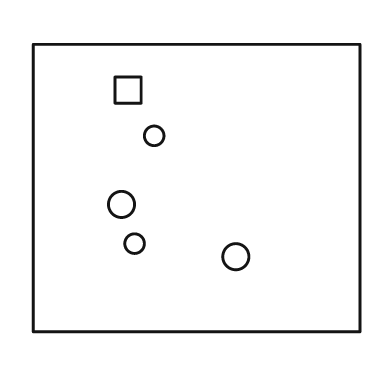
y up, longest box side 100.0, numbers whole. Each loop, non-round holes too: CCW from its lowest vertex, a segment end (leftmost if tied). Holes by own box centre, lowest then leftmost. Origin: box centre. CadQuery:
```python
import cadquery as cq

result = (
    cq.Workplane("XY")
    .moveTo(-50.0, -44.0)
    .lineTo(50.0, -44.0)
    .lineTo(50.0, 44.0)
    .lineTo(-50.0, 44.0)
    .close()
    .moveTo(12.0, -21.0)
    .circle(4.0)
    .moveTo(-19.0, -17.0)
    .circle(3.0)
    .moveTo(-23.0, -5.0)
    .circle(4.0)
    .moveTo(-13.0, 16.0)
    .circle(3.0)
    .moveTo(-25.0, 26.0)
    .lineTo(-17.0, 26.0)
    .lineTo(-17.0, 34.0)
    .lineTo(-25.0, 34.0)
    .close()
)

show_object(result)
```